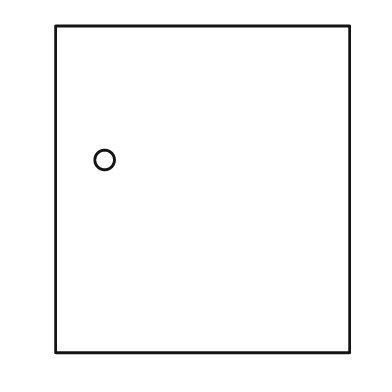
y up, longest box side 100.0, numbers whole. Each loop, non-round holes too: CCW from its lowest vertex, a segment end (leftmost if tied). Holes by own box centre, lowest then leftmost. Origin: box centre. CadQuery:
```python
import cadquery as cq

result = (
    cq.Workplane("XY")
    .moveTo(-45.0, -50.0)
    .lineTo(45.0, -50.0)
    .lineTo(45.0, 50.0)
    .lineTo(-45.0, 50.0)
    .close()
    .moveTo(-30.0, 9.0)
    .circle(3.0)
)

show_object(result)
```